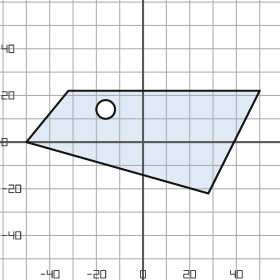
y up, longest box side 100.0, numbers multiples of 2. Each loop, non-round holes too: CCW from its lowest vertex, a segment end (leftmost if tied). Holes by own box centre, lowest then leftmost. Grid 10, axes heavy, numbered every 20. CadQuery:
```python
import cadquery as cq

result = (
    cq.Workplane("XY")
    .moveTo(28.0, -22.0)
    .lineTo(50.0, 22.0)
    .lineTo(-32.0, 22.0)
    .lineTo(-50.0, 0.0)
    .close()
    .moveTo(-16.0, 14.0)
    .circle(4.0)
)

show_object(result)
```